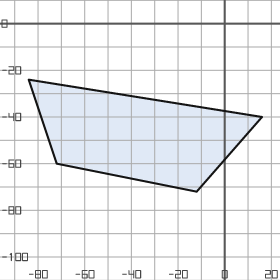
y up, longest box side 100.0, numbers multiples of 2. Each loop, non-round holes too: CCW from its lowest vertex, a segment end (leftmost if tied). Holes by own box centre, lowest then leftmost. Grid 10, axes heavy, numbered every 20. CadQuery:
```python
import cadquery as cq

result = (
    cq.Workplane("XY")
    .moveTo(-12.0, -72.0)
    .lineTo(16.0, -40.0)
    .lineTo(-84.0, -24.0)
    .lineTo(-72.0, -60.0)
    .close()
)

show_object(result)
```